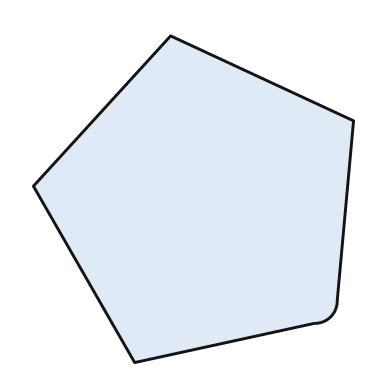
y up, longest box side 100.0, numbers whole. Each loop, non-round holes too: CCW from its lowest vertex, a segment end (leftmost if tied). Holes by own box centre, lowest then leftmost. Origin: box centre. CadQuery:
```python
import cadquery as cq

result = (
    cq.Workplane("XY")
    .moveTo(-18.0, -50.0)
    .lineTo(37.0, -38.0)
    .threePointArc((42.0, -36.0), (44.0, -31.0))
    .lineTo(49.0, 24.0)
    .lineTo(-7.0, 50.0)
    .lineTo(-49.0, 4.0)
    .close()
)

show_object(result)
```